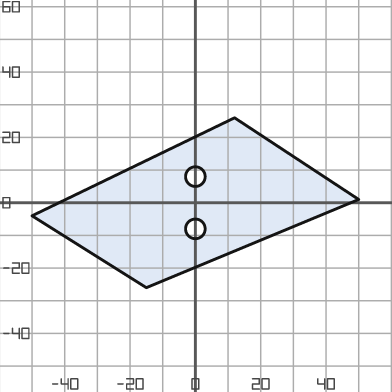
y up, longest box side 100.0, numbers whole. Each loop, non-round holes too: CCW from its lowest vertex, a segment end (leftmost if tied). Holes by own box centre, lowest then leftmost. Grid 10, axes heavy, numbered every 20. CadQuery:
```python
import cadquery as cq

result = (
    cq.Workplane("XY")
    .moveTo(-15.0, -26.0)
    .lineTo(50.0, 1.0)
    .lineTo(12.0, 26.0)
    .lineTo(-50.0, -4.0)
    .close()
    .moveTo(0.0, -8.0)
    .circle(3.0)
    .moveTo(0.0, 8.0)
    .circle(3.0)
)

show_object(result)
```